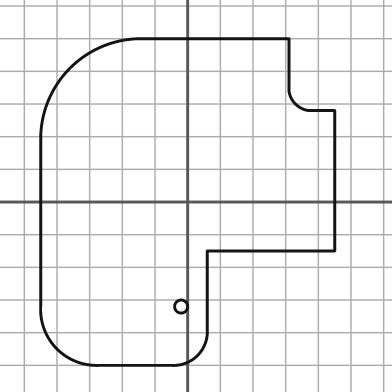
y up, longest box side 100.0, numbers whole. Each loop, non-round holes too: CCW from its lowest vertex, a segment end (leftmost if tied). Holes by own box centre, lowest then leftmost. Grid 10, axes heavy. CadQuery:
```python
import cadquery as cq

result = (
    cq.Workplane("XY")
    .moveTo(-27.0, -50.0)
    .lineTo(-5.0, -50.0)
    .threePointArc((3.0, -47.0), (6.0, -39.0))
    .lineTo(6.0, -15.0)
    .lineTo(45.0, -15.0)
    .lineTo(45.0, 28.0)
    .lineTo(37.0, 28.0)
    .threePointArc((33.0, 30.0), (31.0, 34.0))
    .lineTo(31.0, 50.0)
    .lineTo(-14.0, 50.0)
    .threePointArc((-36.0, 41.0), (-45.0, 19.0))
    .lineTo(-45.0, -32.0)
    .threePointArc((-40.0, -45.0), (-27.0, -50.0))
    .close()
    .moveTo(-2.0, -32.0)
    .circle(2.0)
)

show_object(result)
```